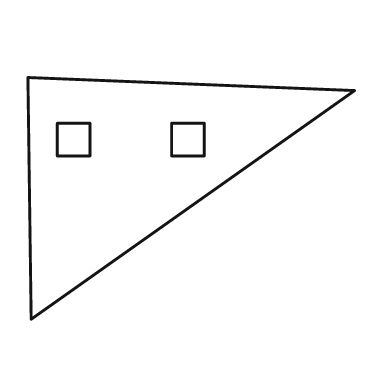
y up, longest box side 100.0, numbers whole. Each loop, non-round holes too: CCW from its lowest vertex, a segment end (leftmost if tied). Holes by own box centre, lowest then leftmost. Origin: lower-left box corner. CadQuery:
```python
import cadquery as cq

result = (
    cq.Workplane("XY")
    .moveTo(1.0, 0.0)
    .lineTo(100.0, 70.0)
    .lineTo(0.0, 74.0)
    .close()
    .moveTo(9.0, 50.0)
    .lineTo(19.0, 50.0)
    .lineTo(19.0, 60.0)
    .lineTo(9.0, 60.0)
    .close()
    .moveTo(44.0, 50.0)
    .lineTo(54.0, 50.0)
    .lineTo(54.0, 60.0)
    .lineTo(44.0, 60.0)
    .close()
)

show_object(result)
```